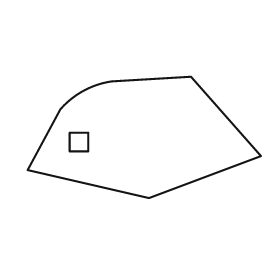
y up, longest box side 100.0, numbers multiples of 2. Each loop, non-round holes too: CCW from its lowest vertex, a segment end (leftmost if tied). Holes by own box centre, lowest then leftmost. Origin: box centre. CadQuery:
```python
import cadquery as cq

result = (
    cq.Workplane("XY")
    .moveTo(2.0, -26.0)
    .lineTo(50.0, -8.0)
    .lineTo(20.0, 26.0)
    .lineTo(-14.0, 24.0)
    .threePointArc((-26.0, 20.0), (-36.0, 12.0))
    .lineTo(-50.0, -14.0)
    .close()
    .moveTo(-32.0, -6.0)
    .lineTo(-24.0, -6.0)
    .lineTo(-24.0, 2.0)
    .lineTo(-32.0, 2.0)
    .close()
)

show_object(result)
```